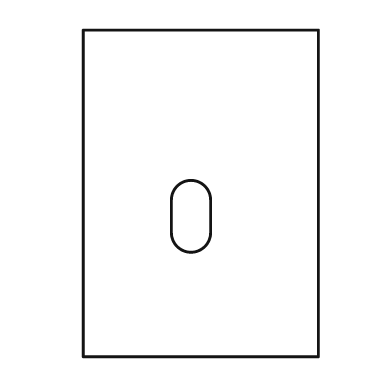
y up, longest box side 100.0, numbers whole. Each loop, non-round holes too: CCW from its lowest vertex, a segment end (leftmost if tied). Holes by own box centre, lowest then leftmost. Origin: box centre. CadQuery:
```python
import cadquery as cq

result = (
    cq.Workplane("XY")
    .moveTo(-36.0, -50.0)
    .lineTo(36.0, -50.0)
    .lineTo(36.0, 50.0)
    .lineTo(-36.0, 50.0)
    .close()
    .moveTo(-9.0, -12.0)
    .threePointArc((-3.0, -18.0), (3.0, -12.0))
    .lineTo(3.0, -2.0)
    .threePointArc((-3.0, 4.0), (-9.0, -2.0))
    .close()
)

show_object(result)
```